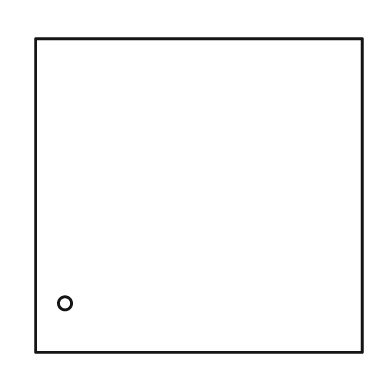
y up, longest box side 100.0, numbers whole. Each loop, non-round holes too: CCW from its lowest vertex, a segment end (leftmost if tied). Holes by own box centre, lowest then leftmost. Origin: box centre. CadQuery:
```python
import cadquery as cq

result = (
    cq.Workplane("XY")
    .moveTo(-50.0, -48.0)
    .lineTo(50.0, -48.0)
    .lineTo(50.0, 48.0)
    .lineTo(-50.0, 48.0)
    .close()
    .moveTo(-41.0, -33.0)
    .circle(2.0)
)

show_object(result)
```